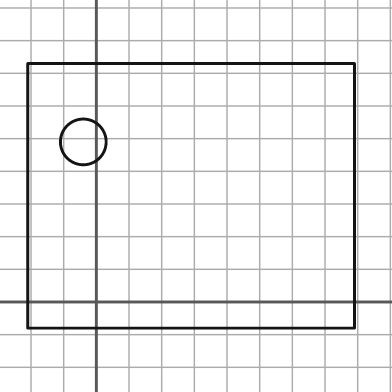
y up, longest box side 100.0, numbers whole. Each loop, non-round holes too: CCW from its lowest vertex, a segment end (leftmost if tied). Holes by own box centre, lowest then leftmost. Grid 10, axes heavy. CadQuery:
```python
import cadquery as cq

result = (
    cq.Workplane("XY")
    .moveTo(-21.0, -8.0)
    .lineTo(79.0, -8.0)
    .lineTo(79.0, 73.0)
    .lineTo(-21.0, 73.0)
    .close()
    .moveTo(-4.0, 49.0)
    .circle(7.0)
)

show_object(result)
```